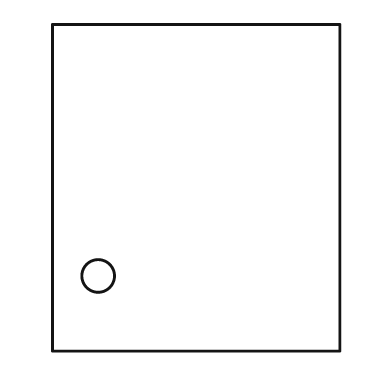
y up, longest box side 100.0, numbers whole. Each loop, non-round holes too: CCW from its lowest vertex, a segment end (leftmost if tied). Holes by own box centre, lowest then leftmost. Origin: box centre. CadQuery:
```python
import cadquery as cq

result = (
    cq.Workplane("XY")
    .moveTo(-44.0, -50.0)
    .lineTo(44.0, -50.0)
    .lineTo(44.0, 50.0)
    .lineTo(-44.0, 50.0)
    .close()
    .moveTo(-30.0, -27.0)
    .circle(5.0)
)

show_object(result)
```